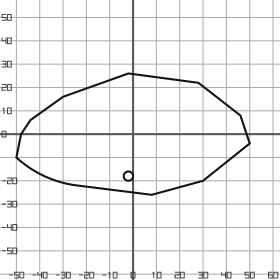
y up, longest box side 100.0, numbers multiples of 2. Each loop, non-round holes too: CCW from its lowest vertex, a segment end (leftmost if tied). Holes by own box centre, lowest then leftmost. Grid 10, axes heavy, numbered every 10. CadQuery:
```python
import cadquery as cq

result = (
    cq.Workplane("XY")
    .moveTo(8.0, -26.0)
    .lineTo(30.0, -20.0)
    .lineTo(50.0, -4.0)
    .lineTo(46.0, 8.0)
    .lineTo(28.0, 22.0)
    .lineTo(-2.0, 26.0)
    .lineTo(-30.0, 16.0)
    .lineTo(-44.0, 6.0)
    .lineTo(-48.0, 0.0)
    .lineTo(-50.0, -10.0)
    .threePointArc((-38.0, -18.0), (-24.0, -22.0))
    .close()
    .moveTo(-2.0, -18.0)
    .circle(2.0)
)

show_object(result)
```